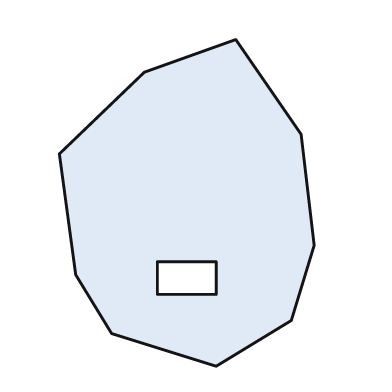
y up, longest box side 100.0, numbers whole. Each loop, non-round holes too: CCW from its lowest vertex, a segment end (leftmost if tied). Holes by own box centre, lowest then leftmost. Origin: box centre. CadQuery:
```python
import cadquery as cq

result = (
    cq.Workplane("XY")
    .moveTo(9.0, -50.0)
    .lineTo(32.0, -36.0)
    .lineTo(39.0, -13.0)
    .lineTo(35.0, 21.0)
    .lineTo(15.0, 50.0)
    .lineTo(-13.0, 40.0)
    .lineTo(-39.0, 15.0)
    .lineTo(-34.0, -22.0)
    .lineTo(-23.0, -40.0)
    .close()
    .moveTo(-9.0, -28.0)
    .lineTo(9.0, -28.0)
    .lineTo(9.0, -18.0)
    .lineTo(-9.0, -18.0)
    .close()
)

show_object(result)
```